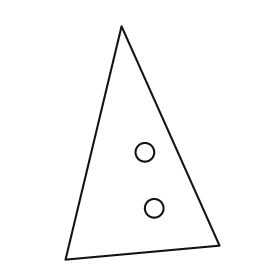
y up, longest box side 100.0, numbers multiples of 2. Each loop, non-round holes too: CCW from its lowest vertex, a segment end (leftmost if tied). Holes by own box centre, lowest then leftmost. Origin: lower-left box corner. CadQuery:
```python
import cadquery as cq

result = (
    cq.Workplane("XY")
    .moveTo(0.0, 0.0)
    .lineTo(66.0, 6.0)
    .lineTo(24.0, 100.0)
    .close()
    .moveTo(38.0, 22.0)
    .circle(4.0)
    .moveTo(34.0, 46.0)
    .circle(4.0)
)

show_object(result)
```